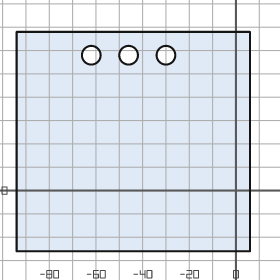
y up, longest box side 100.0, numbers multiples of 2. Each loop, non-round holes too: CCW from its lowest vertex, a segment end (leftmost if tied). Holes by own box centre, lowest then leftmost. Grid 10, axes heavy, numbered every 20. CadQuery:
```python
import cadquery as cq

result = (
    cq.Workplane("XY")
    .moveTo(-94.0, -26.0)
    .lineTo(6.0, -26.0)
    .lineTo(6.0, 68.0)
    .lineTo(-94.0, 68.0)
    .close()
    .moveTo(-62.0, 58.0)
    .circle(4.0)
    .moveTo(-46.0, 58.0)
    .circle(4.0)
    .moveTo(-30.0, 58.0)
    .circle(4.0)
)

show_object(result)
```